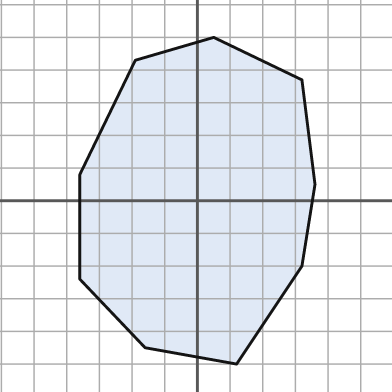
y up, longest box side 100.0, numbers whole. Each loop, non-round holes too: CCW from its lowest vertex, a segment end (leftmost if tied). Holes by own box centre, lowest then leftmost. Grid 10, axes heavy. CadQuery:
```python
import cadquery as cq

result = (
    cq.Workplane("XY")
    .moveTo(12.0, -50.0)
    .lineTo(32.0, -20.0)
    .lineTo(36.0, 5.0)
    .lineTo(32.0, 37.0)
    .lineTo(5.0, 50.0)
    .lineTo(-19.0, 43.0)
    .lineTo(-36.0, 8.0)
    .lineTo(-36.0, -24.0)
    .lineTo(-16.0, -45.0)
    .close()
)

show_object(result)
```